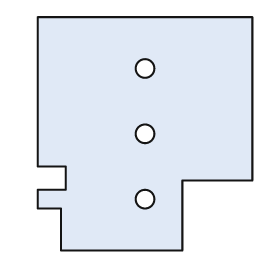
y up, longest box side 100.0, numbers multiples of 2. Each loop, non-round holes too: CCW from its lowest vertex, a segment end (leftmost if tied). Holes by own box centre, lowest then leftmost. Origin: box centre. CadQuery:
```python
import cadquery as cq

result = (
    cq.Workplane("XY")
    .moveTo(-36.0, -50.0)
    .lineTo(16.0, -50.0)
    .lineTo(16.0, -20.0)
    .lineTo(46.0, -20.0)
    .lineTo(46.0, 50.0)
    .lineTo(-46.0, 50.0)
    .lineTo(-46.0, -14.0)
    .lineTo(-34.0, -14.0)
    .lineTo(-34.0, -24.0)
    .lineTo(-46.0, -24.0)
    .lineTo(-46.0, -32.0)
    .lineTo(-36.0, -32.0)
    .close()
    .moveTo(0.0, -28.0)
    .circle(4.0)
    .moveTo(0.0, 0.0)
    .circle(4.0)
    .moveTo(0.0, 28.0)
    .circle(4.0)
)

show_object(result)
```